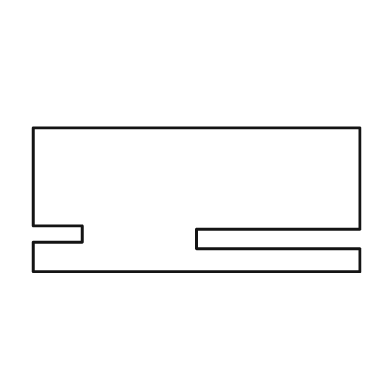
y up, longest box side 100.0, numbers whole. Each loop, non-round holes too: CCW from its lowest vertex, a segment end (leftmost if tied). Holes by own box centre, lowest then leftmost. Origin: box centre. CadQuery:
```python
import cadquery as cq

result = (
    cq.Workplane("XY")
    .moveTo(-50.0, -22.0)
    .lineTo(50.0, -22.0)
    .lineTo(50.0, -15.0)
    .lineTo(0.0, -15.0)
    .lineTo(0.0, -9.0)
    .lineTo(50.0, -9.0)
    .lineTo(50.0, 22.0)
    .lineTo(-50.0, 22.0)
    .lineTo(-50.0, -8.0)
    .lineTo(-35.0, -8.0)
    .lineTo(-35.0, -13.0)
    .lineTo(-50.0, -13.0)
    .close()
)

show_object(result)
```